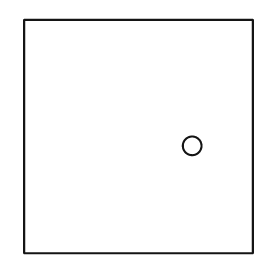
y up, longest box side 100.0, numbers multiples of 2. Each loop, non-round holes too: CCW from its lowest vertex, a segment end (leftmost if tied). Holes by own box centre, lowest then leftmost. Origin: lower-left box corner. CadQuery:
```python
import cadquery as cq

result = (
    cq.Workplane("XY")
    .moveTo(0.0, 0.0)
    .lineTo(98.0, 0.0)
    .lineTo(98.0, 100.0)
    .lineTo(0.0, 100.0)
    .close()
    .moveTo(72.0, 46.0)
    .circle(4.0)
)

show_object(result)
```